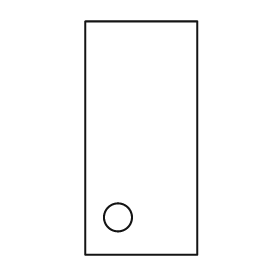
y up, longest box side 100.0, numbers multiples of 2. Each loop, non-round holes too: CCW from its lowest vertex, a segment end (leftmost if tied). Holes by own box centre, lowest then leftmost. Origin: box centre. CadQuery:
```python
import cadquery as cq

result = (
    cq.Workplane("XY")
    .moveTo(-24.0, -50.0)
    .lineTo(24.0, -50.0)
    .lineTo(24.0, 50.0)
    .lineTo(-24.0, 50.0)
    .close()
    .moveTo(-10.0, -34.0)
    .circle(6.0)
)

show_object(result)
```